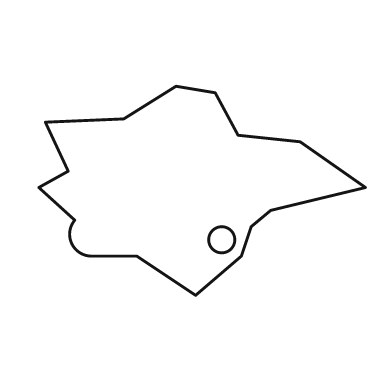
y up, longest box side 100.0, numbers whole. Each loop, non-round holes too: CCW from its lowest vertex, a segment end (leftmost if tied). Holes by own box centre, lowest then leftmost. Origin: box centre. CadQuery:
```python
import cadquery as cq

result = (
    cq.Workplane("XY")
    .moveTo(-2.0, -32.0)
    .lineTo(12.0, -20.0)
    .lineTo(15.0, -11.0)
    .lineTo(21.0, -6.0)
    .lineTo(50.0, 1.0)
    .lineTo(30.0, 15.0)
    .lineTo(11.0, 17.0)
    .lineTo(4.0, 30.0)
    .lineTo(-8.0, 32.0)
    .lineTo(-24.0, 22.0)
    .lineTo(-48.0, 21.0)
    .lineTo(-41.0, 6.0)
    .lineTo(-50.0, 1.0)
    .lineTo(-39.0, -9.0)
    .threePointArc((-40.0, -16.0), (-34.0, -20.0))
    .lineTo(-20.0, -20.0)
    .close()
    .moveTo(6.0, -15.0)
    .circle(4.0)
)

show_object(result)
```